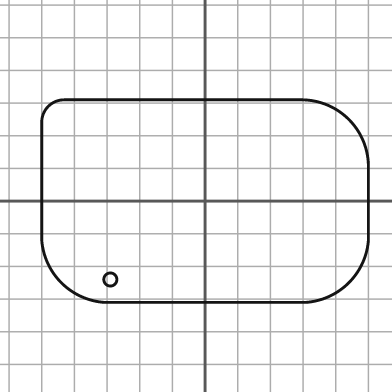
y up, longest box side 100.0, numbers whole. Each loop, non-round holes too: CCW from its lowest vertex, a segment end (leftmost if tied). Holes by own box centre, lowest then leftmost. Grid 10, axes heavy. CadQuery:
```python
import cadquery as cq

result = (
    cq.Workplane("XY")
    .moveTo(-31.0, -31.0)
    .lineTo(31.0, -31.0)
    .threePointArc((44.0, -25.0), (50.0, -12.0))
    .lineTo(50.0, 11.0)
    .threePointArc((44.0, 25.0), (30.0, 31.0))
    .lineTo(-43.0, 31.0)
    .threePointArc((-48.0, 29.0), (-50.0, 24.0))
    .lineTo(-50.0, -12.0)
    .threePointArc((-44.0, -25.0), (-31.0, -31.0))
    .close()
    .moveTo(-29.0, -24.0)
    .circle(2.0)
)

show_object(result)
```